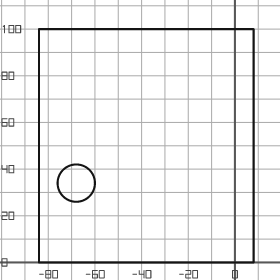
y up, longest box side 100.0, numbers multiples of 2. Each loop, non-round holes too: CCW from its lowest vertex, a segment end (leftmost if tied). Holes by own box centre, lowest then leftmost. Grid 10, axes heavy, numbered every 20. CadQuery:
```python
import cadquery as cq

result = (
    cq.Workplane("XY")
    .moveTo(-84.0, 0.0)
    .lineTo(8.0, 0.0)
    .lineTo(8.0, 100.0)
    .lineTo(-84.0, 100.0)
    .close()
    .moveTo(-68.0, 34.0)
    .circle(8.0)
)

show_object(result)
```